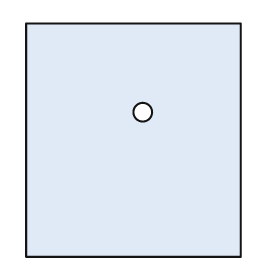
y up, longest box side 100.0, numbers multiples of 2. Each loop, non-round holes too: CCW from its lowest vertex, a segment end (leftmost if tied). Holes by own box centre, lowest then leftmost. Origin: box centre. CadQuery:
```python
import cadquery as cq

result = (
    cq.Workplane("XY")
    .moveTo(-46.0, -50.0)
    .lineTo(46.0, -50.0)
    .lineTo(46.0, 50.0)
    .lineTo(-46.0, 50.0)
    .close()
    .moveTo(4.0, 12.0)
    .circle(4.0)
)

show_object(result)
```